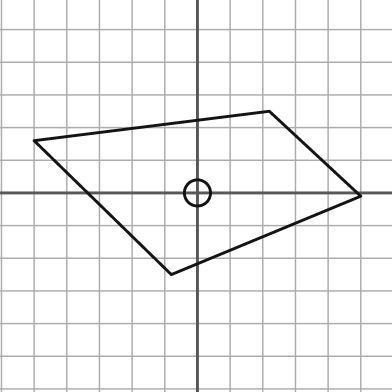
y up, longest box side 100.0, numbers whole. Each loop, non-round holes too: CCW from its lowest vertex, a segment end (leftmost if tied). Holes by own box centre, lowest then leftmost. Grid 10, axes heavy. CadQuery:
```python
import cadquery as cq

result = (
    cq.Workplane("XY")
    .moveTo(-8.0, -25.0)
    .lineTo(50.0, -1.0)
    .lineTo(22.0, 25.0)
    .lineTo(-50.0, 16.0)
    .close()
    .moveTo(0.0, 0.0)
    .circle(4.0)
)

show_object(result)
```